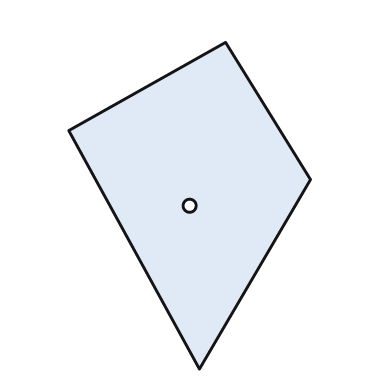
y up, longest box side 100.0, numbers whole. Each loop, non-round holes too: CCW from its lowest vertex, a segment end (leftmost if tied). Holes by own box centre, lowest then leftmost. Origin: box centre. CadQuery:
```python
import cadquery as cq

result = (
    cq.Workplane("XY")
    .moveTo(3.0, -50.0)
    .lineTo(37.0, 8.0)
    .lineTo(11.0, 50.0)
    .lineTo(-37.0, 23.0)
    .close()
    .moveTo(0.0, 0.0)
    .circle(2.0)
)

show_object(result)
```